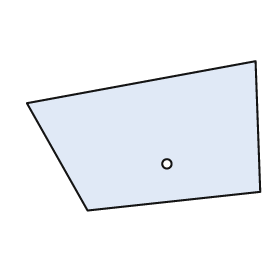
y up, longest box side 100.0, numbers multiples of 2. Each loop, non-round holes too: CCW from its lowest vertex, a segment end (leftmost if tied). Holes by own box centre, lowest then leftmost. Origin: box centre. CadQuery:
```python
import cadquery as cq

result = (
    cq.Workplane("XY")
    .moveTo(-24.0, -32.0)
    .lineTo(50.0, -24.0)
    .lineTo(48.0, 32.0)
    .lineTo(-50.0, 14.0)
    .close()
    .moveTo(10.0, -12.0)
    .circle(2.0)
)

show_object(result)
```